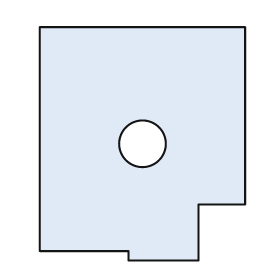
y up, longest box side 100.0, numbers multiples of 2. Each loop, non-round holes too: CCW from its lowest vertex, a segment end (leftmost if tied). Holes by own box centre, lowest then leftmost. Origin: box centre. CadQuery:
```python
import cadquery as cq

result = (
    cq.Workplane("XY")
    .moveTo(-6.0, -50.0)
    .lineTo(24.0, -50.0)
    .lineTo(24.0, -26.0)
    .lineTo(44.0, -26.0)
    .lineTo(44.0, 50.0)
    .lineTo(-44.0, 50.0)
    .lineTo(-44.0, -46.0)
    .lineTo(-6.0, -46.0)
    .close()
    .moveTo(0.0, 0.0)
    .circle(10.0)
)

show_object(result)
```